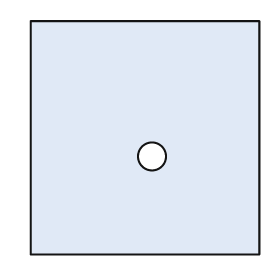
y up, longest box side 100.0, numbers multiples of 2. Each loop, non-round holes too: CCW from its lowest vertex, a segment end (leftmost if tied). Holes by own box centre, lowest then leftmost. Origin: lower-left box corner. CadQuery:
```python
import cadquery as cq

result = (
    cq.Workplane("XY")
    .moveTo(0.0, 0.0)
    .lineTo(98.0, 0.0)
    .lineTo(98.0, 100.0)
    .lineTo(0.0, 100.0)
    .close()
    .moveTo(52.0, 42.0)
    .circle(6.0)
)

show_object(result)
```